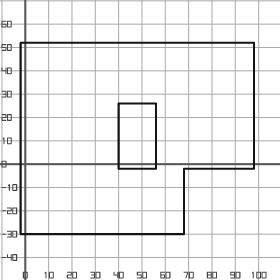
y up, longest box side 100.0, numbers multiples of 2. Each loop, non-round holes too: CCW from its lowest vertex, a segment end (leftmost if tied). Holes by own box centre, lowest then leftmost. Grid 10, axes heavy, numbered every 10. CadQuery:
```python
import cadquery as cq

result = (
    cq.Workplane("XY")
    .moveTo(-2.0, -30.0)
    .lineTo(68.0, -30.0)
    .lineTo(68.0, -2.0)
    .lineTo(98.0, -2.0)
    .lineTo(98.0, 52.0)
    .lineTo(-2.0, 52.0)
    .close()
    .moveTo(40.0, -2.0)
    .lineTo(56.0, -2.0)
    .lineTo(56.0, 26.0)
    .lineTo(40.0, 26.0)
    .close()
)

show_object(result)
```